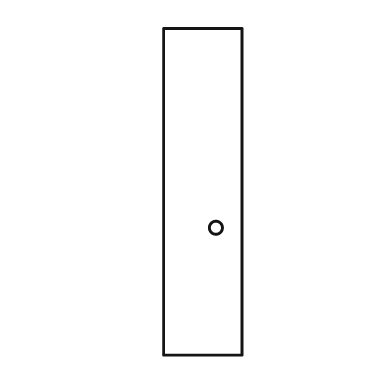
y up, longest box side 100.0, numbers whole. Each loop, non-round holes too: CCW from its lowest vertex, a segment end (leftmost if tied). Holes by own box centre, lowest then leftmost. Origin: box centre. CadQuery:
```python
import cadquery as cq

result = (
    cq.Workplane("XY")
    .moveTo(-12.0, -50.0)
    .lineTo(12.0, -50.0)
    .lineTo(12.0, 50.0)
    .lineTo(-12.0, 50.0)
    .close()
    .moveTo(4.0, -11.0)
    .circle(2.0)
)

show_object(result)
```